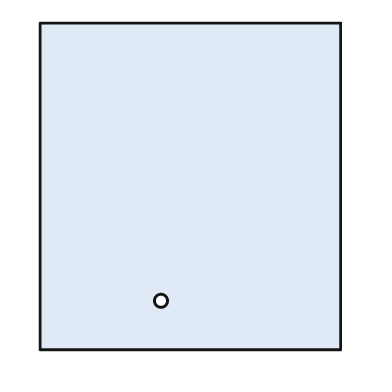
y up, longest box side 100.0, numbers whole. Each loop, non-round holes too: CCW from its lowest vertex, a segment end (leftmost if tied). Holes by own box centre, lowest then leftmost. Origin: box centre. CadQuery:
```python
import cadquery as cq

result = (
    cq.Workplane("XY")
    .moveTo(-46.0, -50.0)
    .lineTo(46.0, -50.0)
    .lineTo(46.0, 50.0)
    .lineTo(-46.0, 50.0)
    .close()
    .moveTo(-9.0, -35.0)
    .circle(2.0)
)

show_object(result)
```